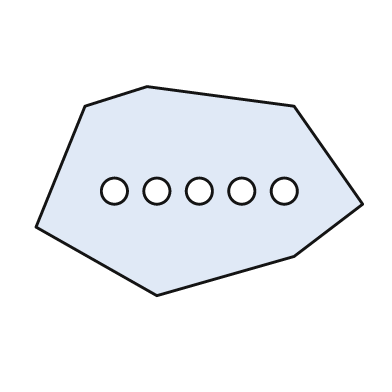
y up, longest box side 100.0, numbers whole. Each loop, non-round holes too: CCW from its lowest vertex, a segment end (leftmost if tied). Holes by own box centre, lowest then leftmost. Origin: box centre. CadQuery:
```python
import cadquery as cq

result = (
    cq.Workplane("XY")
    .moveTo(-13.0, -32.0)
    .lineTo(29.0, -20.0)
    .lineTo(50.0, -4.0)
    .lineTo(29.0, 26.0)
    .lineTo(-16.0, 32.0)
    .lineTo(-35.0, 26.0)
    .lineTo(-50.0, -11.0)
    .close()
    .moveTo(-26.0, 0.0)
    .circle(4.0)
    .moveTo(-13.0, 0.0)
    .circle(4.0)
    .moveTo(0.0, 0.0)
    .circle(4.0)
    .moveTo(13.0, 0.0)
    .circle(4.0)
    .moveTo(26.0, 0.0)
    .circle(4.0)
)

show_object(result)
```